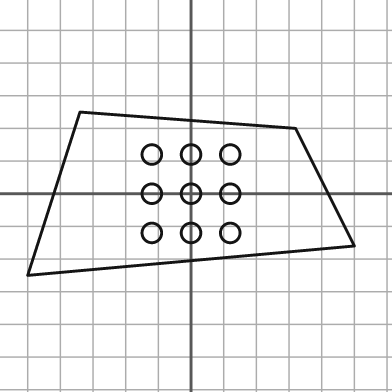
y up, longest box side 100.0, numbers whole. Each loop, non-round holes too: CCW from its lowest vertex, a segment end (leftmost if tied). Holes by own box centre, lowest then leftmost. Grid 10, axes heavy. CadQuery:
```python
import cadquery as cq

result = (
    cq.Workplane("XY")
    .moveTo(-50.0, -25.0)
    .lineTo(50.0, -16.0)
    .lineTo(32.0, 20.0)
    .lineTo(-34.0, 25.0)
    .close()
    .moveTo(-12.0, -12.0)
    .circle(3.0)
    .moveTo(0.0, -12.0)
    .circle(3.0)
    .moveTo(12.0, -12.0)
    .circle(3.0)
    .moveTo(-12.0, 0.0)
    .circle(3.0)
    .moveTo(0.0, 0.0)
    .circle(3.0)
    .moveTo(12.0, 0.0)
    .circle(3.0)
    .moveTo(-12.0, 12.0)
    .circle(3.0)
    .moveTo(0.0, 12.0)
    .circle(3.0)
    .moveTo(12.0, 12.0)
    .circle(3.0)
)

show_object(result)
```